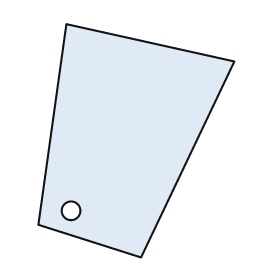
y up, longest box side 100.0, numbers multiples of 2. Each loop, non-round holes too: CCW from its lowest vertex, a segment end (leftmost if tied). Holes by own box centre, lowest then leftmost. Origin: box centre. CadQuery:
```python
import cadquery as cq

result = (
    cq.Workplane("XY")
    .moveTo(2.0, -50.0)
    .lineTo(42.0, 34.0)
    .lineTo(-30.0, 50.0)
    .lineTo(-42.0, -36.0)
    .close()
    .moveTo(-28.0, -30.0)
    .circle(4.0)
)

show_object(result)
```